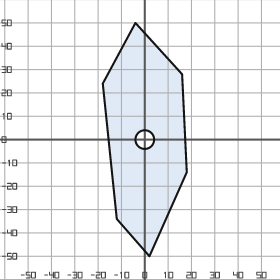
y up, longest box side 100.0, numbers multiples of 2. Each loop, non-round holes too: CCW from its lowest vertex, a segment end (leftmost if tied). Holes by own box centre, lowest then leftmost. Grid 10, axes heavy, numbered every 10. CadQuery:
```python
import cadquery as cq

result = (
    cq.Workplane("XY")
    .moveTo(2.0, -50.0)
    .lineTo(18.0, -14.0)
    .lineTo(16.0, 28.0)
    .lineTo(-4.0, 50.0)
    .lineTo(-18.0, 24.0)
    .lineTo(-12.0, -34.0)
    .close()
    .moveTo(0.0, 0.0)
    .circle(4.0)
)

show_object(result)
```